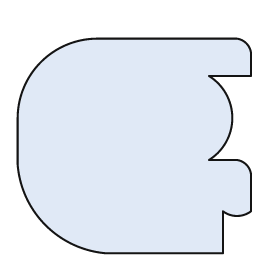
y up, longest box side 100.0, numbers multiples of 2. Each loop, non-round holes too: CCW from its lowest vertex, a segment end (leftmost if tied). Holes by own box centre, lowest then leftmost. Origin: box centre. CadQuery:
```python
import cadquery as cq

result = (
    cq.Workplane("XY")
    .moveTo(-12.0, -46.0)
    .lineTo(38.0, -46.0)
    .lineTo(38.0, -28.0)
    .threePointArc((44.0, -30.0), (50.0, -28.0))
    .lineTo(50.0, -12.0)
    .threePointArc((48.0, -8.0), (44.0, -6.0))
    .lineTo(32.0, -6.0)
    .threePointArc((42.0, 12.0), (32.0, 30.0))
    .lineTo(50.0, 30.0)
    .lineTo(50.0, 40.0)
    .threePointArc((48.0, 44.0), (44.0, 46.0))
    .lineTo(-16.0, 46.0)
    .threePointArc((-40.0, 36.0), (-50.0, 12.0))
    .lineTo(-50.0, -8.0)
    .threePointArc((-38.0, -34.0), (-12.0, -46.0))
    .close()
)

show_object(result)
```